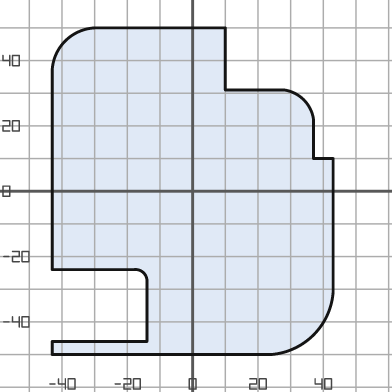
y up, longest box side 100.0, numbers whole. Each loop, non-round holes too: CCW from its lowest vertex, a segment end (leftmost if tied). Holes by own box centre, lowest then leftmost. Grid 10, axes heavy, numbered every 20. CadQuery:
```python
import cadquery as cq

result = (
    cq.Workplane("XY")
    .moveTo(-43.0, -50.0)
    .lineTo(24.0, -50.0)
    .threePointArc((37.0, -44.0), (43.0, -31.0))
    .lineTo(43.0, 10.0)
    .lineTo(37.0, 10.0)
    .lineTo(37.0, 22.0)
    .threePointArc((34.0, 28.0), (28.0, 31.0))
    .lineTo(10.0, 31.0)
    .lineTo(10.0, 50.0)
    .lineTo(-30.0, 50.0)
    .threePointArc((-39.0, 46.0), (-43.0, 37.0))
    .lineTo(-43.0, -24.0)
    .lineTo(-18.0, -24.0)
    .threePointArc((-15.0, -25.0), (-14.0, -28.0))
    .lineTo(-14.0, -46.0)
    .lineTo(-43.0, -46.0)
    .close()
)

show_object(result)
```